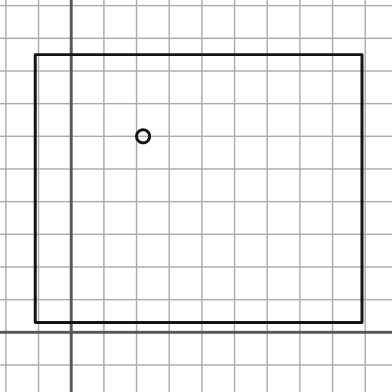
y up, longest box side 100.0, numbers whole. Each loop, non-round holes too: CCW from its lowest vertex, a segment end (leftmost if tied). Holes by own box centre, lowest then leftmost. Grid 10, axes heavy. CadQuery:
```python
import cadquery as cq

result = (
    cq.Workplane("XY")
    .moveTo(-11.0, 3.0)
    .lineTo(89.0, 3.0)
    .lineTo(89.0, 85.0)
    .lineTo(-11.0, 85.0)
    .close()
    .moveTo(22.0, 60.0)
    .circle(2.0)
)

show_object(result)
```